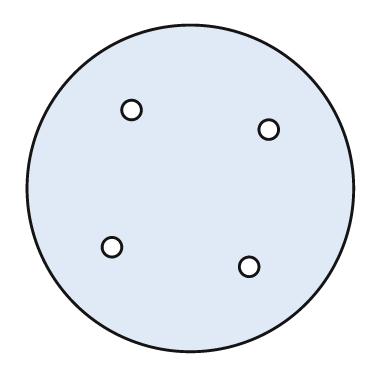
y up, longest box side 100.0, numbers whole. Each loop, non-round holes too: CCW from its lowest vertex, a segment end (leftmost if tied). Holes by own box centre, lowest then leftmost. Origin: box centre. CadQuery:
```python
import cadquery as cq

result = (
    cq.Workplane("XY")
    .moveTo(0.0, 0.0)
    .circle(50.0)
    .moveTo(18.0, -24.0)
    .circle(3.0)
    .moveTo(-24.0, -18.0)
    .circle(3.0)
    .moveTo(24.0, 18.0)
    .circle(3.0)
    .moveTo(-18.0, 24.0)
    .circle(3.0)
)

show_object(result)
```